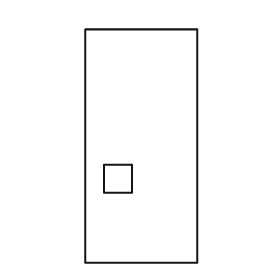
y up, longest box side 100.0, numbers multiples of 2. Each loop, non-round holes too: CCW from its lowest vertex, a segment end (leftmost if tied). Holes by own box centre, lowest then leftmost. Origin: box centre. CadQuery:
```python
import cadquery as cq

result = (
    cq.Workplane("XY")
    .moveTo(-24.0, -50.0)
    .lineTo(24.0, -50.0)
    .lineTo(24.0, 50.0)
    .lineTo(-24.0, 50.0)
    .close()
    .moveTo(-16.0, -20.0)
    .lineTo(-4.0, -20.0)
    .lineTo(-4.0, -8.0)
    .lineTo(-16.0, -8.0)
    .close()
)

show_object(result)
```